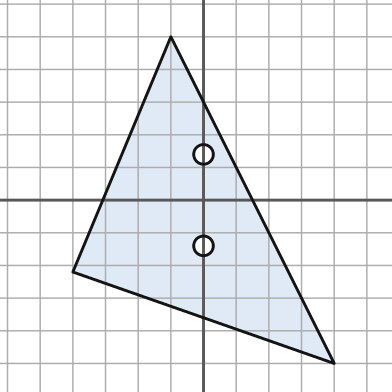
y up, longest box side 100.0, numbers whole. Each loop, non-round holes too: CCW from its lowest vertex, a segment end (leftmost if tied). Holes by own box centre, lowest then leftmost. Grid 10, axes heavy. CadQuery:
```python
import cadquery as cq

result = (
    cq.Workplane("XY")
    .moveTo(40.0, -50.0)
    .lineTo(-10.0, 50.0)
    .lineTo(-40.0, -22.0)
    .close()
    .moveTo(0.0, -14.0)
    .circle(3.0)
    .moveTo(0.0, 14.0)
    .circle(3.0)
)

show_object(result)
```